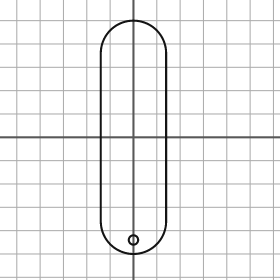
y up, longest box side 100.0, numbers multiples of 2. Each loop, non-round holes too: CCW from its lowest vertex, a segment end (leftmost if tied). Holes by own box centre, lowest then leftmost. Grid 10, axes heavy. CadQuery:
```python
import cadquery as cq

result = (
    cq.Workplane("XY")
    .moveTo(-14.0, -36.0)
    .threePointArc((0.0, -50.0), (14.0, -36.0))
    .lineTo(14.0, 36.0)
    .threePointArc((0.0, 50.0), (-14.0, 36.0))
    .close()
    .moveTo(0.0, -44.0)
    .circle(2.0)
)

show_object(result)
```